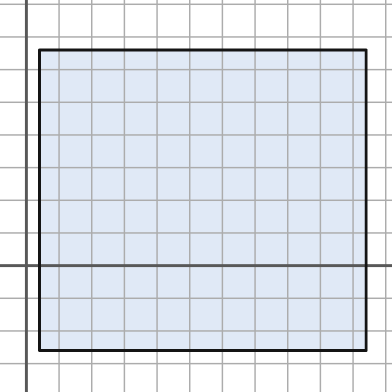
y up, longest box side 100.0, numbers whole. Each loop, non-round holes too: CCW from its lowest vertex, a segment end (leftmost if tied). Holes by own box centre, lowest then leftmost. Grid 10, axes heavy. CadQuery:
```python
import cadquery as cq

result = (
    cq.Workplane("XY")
    .moveTo(4.0, -26.0)
    .lineTo(104.0, -26.0)
    .lineTo(104.0, 66.0)
    .lineTo(4.0, 66.0)
    .close()
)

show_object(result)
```